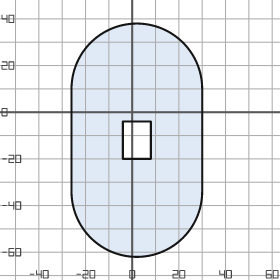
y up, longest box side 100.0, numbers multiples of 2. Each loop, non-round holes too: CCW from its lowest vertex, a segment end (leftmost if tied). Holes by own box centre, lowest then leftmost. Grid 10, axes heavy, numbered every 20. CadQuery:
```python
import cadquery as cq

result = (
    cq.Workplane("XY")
    .moveTo(-26.0, -34.0)
    .threePointArc((2.0, -62.0), (30.0, -34.0))
    .lineTo(30.0, 10.0)
    .threePointArc((2.0, 38.0), (-26.0, 10.0))
    .close()
    .moveTo(-4.0, -20.0)
    .lineTo(8.0, -20.0)
    .lineTo(8.0, -4.0)
    .lineTo(-4.0, -4.0)
    .close()
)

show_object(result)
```